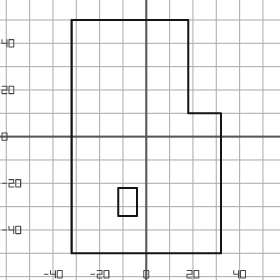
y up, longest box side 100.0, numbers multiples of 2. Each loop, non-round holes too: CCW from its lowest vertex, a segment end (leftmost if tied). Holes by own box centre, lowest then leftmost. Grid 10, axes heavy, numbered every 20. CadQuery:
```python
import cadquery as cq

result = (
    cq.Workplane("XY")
    .moveTo(-32.0, -50.0)
    .lineTo(32.0, -50.0)
    .lineTo(32.0, 10.0)
    .lineTo(18.0, 10.0)
    .lineTo(18.0, 50.0)
    .lineTo(-32.0, 50.0)
    .close()
    .moveTo(-12.0, -34.0)
    .lineTo(-4.0, -34.0)
    .lineTo(-4.0, -22.0)
    .lineTo(-12.0, -22.0)
    .close()
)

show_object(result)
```